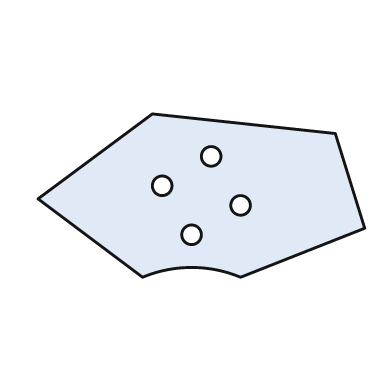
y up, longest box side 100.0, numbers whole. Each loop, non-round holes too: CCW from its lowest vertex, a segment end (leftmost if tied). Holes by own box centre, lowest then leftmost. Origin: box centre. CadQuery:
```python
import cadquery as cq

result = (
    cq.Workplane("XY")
    .moveTo(-18.0, -25.0)
    .threePointArc((-3.0, -22.0), (12.0, -25.0))
    .lineTo(50.0, -10.0)
    .lineTo(41.0, 19.0)
    .lineTo(-15.0, 25.0)
    .lineTo(-50.0, -1.0)
    .close()
    .moveTo(-3.0, -12.0)
    .circle(3.0)
    .moveTo(12.0, -3.0)
    .circle(3.0)
    .moveTo(-12.0, 3.0)
    .circle(3.0)
    .moveTo(3.0, 12.0)
    .circle(3.0)
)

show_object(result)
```